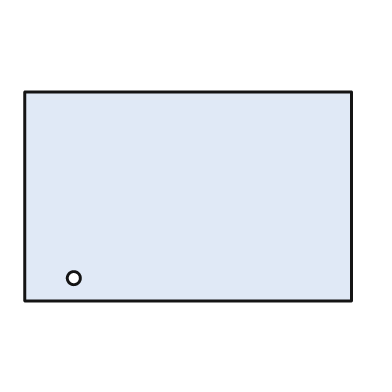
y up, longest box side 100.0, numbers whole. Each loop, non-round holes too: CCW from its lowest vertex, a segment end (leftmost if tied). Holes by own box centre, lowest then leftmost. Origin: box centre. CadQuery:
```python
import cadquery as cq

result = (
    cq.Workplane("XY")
    .moveTo(-50.0, -32.0)
    .lineTo(50.0, -32.0)
    .lineTo(50.0, 32.0)
    .lineTo(-50.0, 32.0)
    .close()
    .moveTo(-35.0, -25.0)
    .circle(2.0)
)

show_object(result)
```